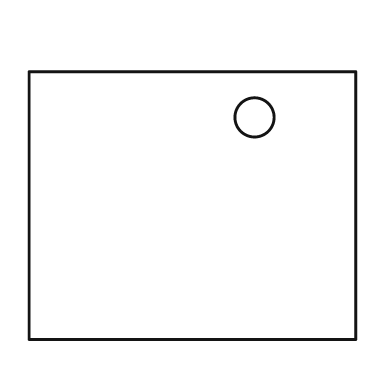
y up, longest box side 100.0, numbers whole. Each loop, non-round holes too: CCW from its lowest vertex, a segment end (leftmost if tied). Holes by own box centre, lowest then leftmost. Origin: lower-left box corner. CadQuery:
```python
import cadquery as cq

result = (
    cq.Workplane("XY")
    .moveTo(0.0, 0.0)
    .lineTo(100.0, 0.0)
    .lineTo(100.0, 82.0)
    .lineTo(0.0, 82.0)
    .close()
    .moveTo(69.0, 68.0)
    .circle(6.0)
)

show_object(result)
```